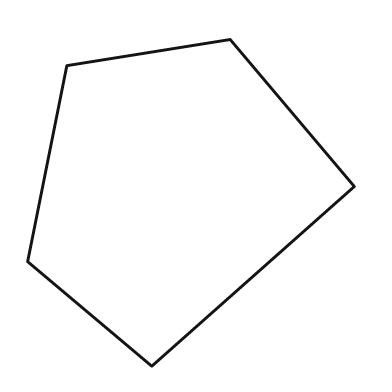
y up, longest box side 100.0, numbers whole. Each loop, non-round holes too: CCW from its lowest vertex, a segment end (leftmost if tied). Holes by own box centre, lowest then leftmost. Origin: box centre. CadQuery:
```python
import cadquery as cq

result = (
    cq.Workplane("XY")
    .moveTo(-12.0, -50.0)
    .lineTo(50.0, 5.0)
    .lineTo(12.0, 50.0)
    .lineTo(-38.0, 42.0)
    .lineTo(-50.0, -18.0)
    .close()
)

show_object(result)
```